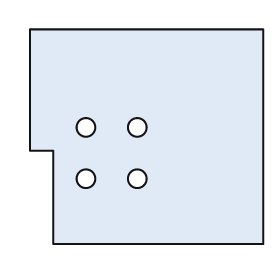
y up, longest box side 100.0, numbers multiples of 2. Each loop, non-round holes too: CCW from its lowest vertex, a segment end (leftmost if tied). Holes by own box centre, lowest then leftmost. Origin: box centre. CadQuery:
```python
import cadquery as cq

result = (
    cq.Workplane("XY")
    .moveTo(-40.0, -46.0)
    .lineTo(50.0, -46.0)
    .lineTo(50.0, 46.0)
    .lineTo(-50.0, 46.0)
    .lineTo(-50.0, -6.0)
    .lineTo(-40.0, -6.0)
    .close()
    .moveTo(-26.0, -18.0)
    .circle(4.0)
    .moveTo(-4.0, -18.0)
    .circle(4.0)
    .moveTo(-26.0, 4.0)
    .circle(4.0)
    .moveTo(-4.0, 4.0)
    .circle(4.0)
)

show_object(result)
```